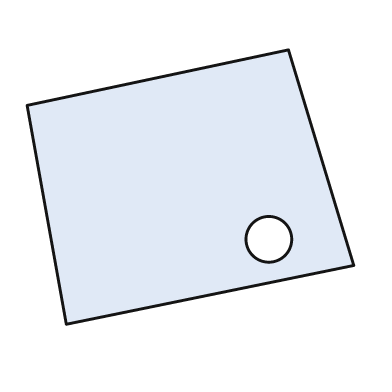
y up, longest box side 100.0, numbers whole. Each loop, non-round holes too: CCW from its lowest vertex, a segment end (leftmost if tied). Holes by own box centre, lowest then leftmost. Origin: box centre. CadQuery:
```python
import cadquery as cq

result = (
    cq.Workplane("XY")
    .moveTo(-38.0, -42.0)
    .lineTo(50.0, -24.0)
    .lineTo(30.0, 42.0)
    .lineTo(-50.0, 25.0)
    .close()
    .moveTo(24.0, -16.0)
    .circle(7.0)
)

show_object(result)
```